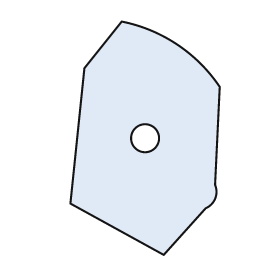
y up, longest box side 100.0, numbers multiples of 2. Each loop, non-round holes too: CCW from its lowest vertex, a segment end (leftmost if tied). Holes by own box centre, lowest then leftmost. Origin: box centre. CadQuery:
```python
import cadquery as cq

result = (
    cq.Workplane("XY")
    .moveTo(8.0, -50.0)
    .lineTo(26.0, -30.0)
    .threePointArc((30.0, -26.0), (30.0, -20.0))
    .lineTo(32.0, 22.0)
    .threePointArc((14.0, 40.0), (-10.0, 50.0))
    .lineTo(-26.0, 30.0)
    .lineTo(-32.0, -28.0)
    .close()
    .moveTo(0.0, 0.0)
    .circle(6.0)
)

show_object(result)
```